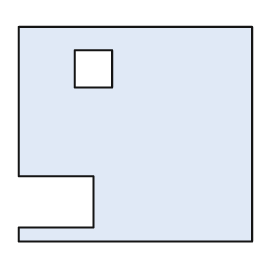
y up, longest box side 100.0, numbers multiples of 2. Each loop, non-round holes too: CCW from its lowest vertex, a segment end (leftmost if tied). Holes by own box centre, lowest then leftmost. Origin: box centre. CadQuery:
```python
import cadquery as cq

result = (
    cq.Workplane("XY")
    .moveTo(-50.0, -46.0)
    .lineTo(50.0, -46.0)
    .lineTo(50.0, 46.0)
    .lineTo(-50.0, 46.0)
    .lineTo(-50.0, -18.0)
    .lineTo(-18.0, -18.0)
    .lineTo(-18.0, -40.0)
    .lineTo(-50.0, -40.0)
    .close()
    .moveTo(-26.0, 20.0)
    .lineTo(-10.0, 20.0)
    .lineTo(-10.0, 36.0)
    .lineTo(-26.0, 36.0)
    .close()
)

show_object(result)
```